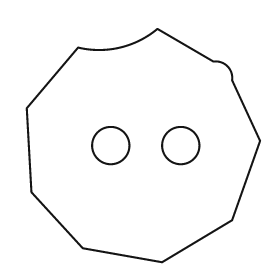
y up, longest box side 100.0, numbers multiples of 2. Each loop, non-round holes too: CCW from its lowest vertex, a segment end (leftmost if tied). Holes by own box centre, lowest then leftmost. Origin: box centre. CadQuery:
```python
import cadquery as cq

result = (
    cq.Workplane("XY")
    .moveTo(8.0, -50.0)
    .lineTo(38.0, -32.0)
    .lineTo(50.0, 2.0)
    .lineTo(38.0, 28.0)
    .threePointArc((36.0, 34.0), (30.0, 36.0))
    .lineTo(6.0, 50.0)
    .threePointArc((-10.0, 42.0), (-28.0, 42.0))
    .lineTo(-50.0, 16.0)
    .lineTo(-48.0, -20.0)
    .lineTo(-26.0, -44.0)
    .close()
    .moveTo(-14.0, 0.0)
    .circle(8.0)
    .moveTo(16.0, 0.0)
    .circle(8.0)
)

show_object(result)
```